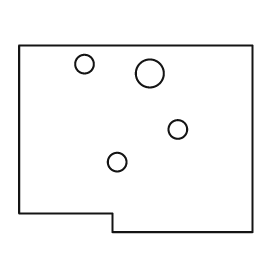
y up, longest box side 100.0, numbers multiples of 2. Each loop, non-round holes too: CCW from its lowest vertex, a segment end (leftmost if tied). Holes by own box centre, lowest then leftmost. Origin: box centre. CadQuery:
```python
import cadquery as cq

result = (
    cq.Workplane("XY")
    .moveTo(-10.0, -40.0)
    .lineTo(50.0, -40.0)
    .lineTo(50.0, 40.0)
    .lineTo(-50.0, 40.0)
    .lineTo(-50.0, -32.0)
    .lineTo(-10.0, -32.0)
    .close()
    .moveTo(-8.0, -10.0)
    .circle(4.0)
    .moveTo(18.0, 4.0)
    .circle(4.0)
    .moveTo(6.0, 28.0)
    .circle(6.0)
    .moveTo(-22.0, 32.0)
    .circle(4.0)
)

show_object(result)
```